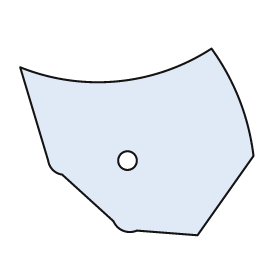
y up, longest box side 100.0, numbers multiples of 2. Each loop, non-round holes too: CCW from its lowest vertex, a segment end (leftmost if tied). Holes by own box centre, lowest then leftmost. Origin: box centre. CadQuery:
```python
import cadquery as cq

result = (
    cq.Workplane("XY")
    .moveTo(26.0, -40.0)
    .lineTo(50.0, -6.0)
    .threePointArc((44.0, 18.0), (32.0, 40.0))
    .threePointArc((-8.0, 26.0), (-50.0, 32.0))
    .lineTo(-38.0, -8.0)
    .threePointArc((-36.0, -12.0), (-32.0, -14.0))
    .lineTo(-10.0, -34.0)
    .threePointArc((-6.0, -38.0), (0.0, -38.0))
    .close()
    .moveTo(-4.0, -8.0)
    .circle(4.0)
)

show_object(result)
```